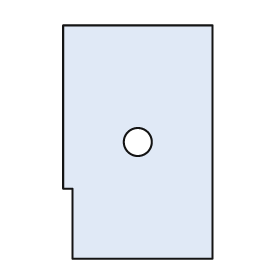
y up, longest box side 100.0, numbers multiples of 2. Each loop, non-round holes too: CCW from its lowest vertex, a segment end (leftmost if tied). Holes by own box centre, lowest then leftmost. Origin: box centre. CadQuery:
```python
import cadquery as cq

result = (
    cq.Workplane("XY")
    .moveTo(-28.0, -50.0)
    .lineTo(32.0, -50.0)
    .lineTo(32.0, 50.0)
    .lineTo(-32.0, 50.0)
    .lineTo(-32.0, -20.0)
    .lineTo(-28.0, -20.0)
    .close()
    .moveTo(0.0, 0.0)
    .circle(6.0)
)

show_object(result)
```